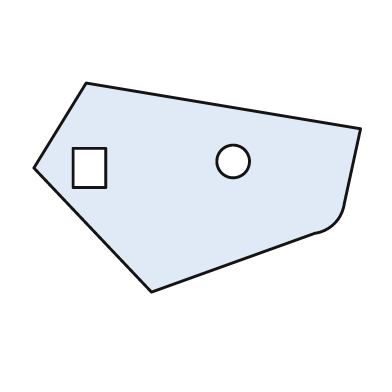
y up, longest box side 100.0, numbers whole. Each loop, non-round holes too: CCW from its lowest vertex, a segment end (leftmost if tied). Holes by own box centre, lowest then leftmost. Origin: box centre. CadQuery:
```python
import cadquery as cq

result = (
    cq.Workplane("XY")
    .moveTo(-14.0, -32.0)
    .lineTo(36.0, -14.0)
    .threePointArc((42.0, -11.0), (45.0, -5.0))
    .lineTo(50.0, 18.0)
    .lineTo(-34.0, 32.0)
    .lineTo(-50.0, 6.0)
    .close()
    .moveTo(-38.0, 0.0)
    .lineTo(-28.0, 0.0)
    .lineTo(-28.0, 12.0)
    .lineTo(-38.0, 12.0)
    .close()
    .moveTo(11.0, 8.0)
    .circle(5.0)
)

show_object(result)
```